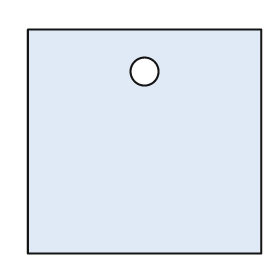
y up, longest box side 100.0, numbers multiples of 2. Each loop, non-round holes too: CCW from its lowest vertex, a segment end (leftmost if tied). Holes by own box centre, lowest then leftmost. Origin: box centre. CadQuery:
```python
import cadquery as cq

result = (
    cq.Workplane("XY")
    .moveTo(-50.0, -48.0)
    .lineTo(50.0, -48.0)
    .lineTo(50.0, 48.0)
    .lineTo(-50.0, 48.0)
    .close()
    .moveTo(0.0, 30.0)
    .circle(6.0)
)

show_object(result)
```